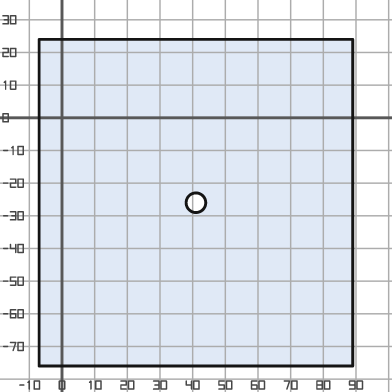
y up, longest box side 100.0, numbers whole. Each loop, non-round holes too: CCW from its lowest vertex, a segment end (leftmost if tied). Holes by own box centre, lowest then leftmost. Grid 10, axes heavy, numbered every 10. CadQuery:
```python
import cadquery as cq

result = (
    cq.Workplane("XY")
    .moveTo(-7.0, -76.0)
    .lineTo(89.0, -76.0)
    .lineTo(89.0, 24.0)
    .lineTo(-7.0, 24.0)
    .close()
    .moveTo(41.0, -26.0)
    .circle(3.0)
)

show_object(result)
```